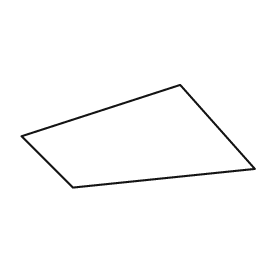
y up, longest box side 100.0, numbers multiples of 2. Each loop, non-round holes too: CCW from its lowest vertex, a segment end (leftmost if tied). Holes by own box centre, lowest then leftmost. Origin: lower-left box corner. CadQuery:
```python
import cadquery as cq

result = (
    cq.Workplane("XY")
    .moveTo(22.0, 0.0)
    .lineTo(100.0, 8.0)
    .lineTo(68.0, 44.0)
    .lineTo(0.0, 22.0)
    .close()
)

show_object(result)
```